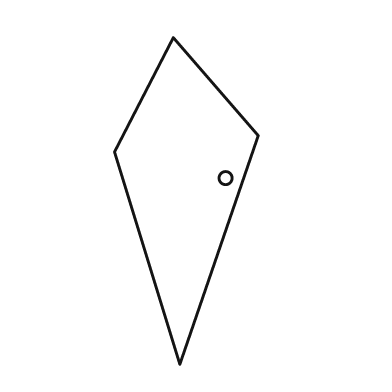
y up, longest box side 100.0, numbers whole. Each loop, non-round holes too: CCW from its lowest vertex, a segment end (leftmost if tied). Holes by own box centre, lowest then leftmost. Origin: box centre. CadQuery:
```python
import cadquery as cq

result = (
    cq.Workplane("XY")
    .moveTo(-2.0, -50.0)
    .lineTo(22.0, 20.0)
    .lineTo(-4.0, 50.0)
    .lineTo(-22.0, 15.0)
    .close()
    .moveTo(12.0, 7.0)
    .circle(2.0)
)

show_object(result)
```